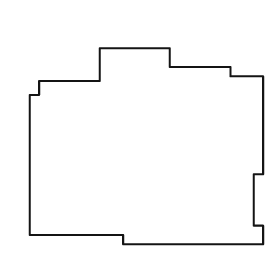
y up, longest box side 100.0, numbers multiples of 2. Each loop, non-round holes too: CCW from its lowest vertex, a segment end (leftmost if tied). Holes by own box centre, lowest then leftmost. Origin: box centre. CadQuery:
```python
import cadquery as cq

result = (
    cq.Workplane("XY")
    .moveTo(-10.0, -42.0)
    .lineTo(50.0, -42.0)
    .lineTo(50.0, -34.0)
    .lineTo(46.0, -34.0)
    .lineTo(46.0, -12.0)
    .lineTo(50.0, -12.0)
    .lineTo(50.0, 30.0)
    .lineTo(36.0, 30.0)
    .lineTo(36.0, 34.0)
    .lineTo(10.0, 34.0)
    .lineTo(10.0, 42.0)
    .lineTo(-20.0, 42.0)
    .lineTo(-20.0, 28.0)
    .lineTo(-46.0, 28.0)
    .lineTo(-46.0, 22.0)
    .lineTo(-50.0, 22.0)
    .lineTo(-50.0, -38.0)
    .lineTo(-10.0, -38.0)
    .close()
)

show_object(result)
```